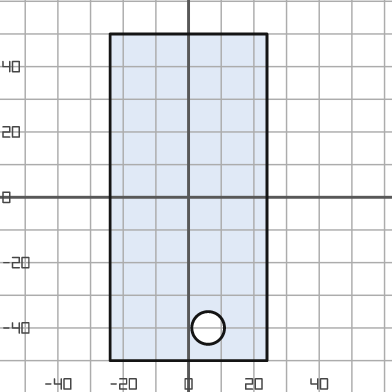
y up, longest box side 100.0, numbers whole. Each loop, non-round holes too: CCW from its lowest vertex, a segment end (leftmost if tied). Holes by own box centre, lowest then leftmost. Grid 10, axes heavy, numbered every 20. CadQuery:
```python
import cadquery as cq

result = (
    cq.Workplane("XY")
    .moveTo(-24.0, -50.0)
    .lineTo(24.0, -50.0)
    .lineTo(24.0, 50.0)
    .lineTo(-24.0, 50.0)
    .close()
    .moveTo(6.0, -40.0)
    .circle(5.0)
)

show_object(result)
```